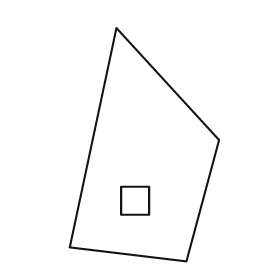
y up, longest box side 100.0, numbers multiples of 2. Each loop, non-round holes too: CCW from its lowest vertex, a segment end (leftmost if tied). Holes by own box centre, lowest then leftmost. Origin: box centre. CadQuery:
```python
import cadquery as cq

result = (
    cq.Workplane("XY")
    .moveTo(18.0, -50.0)
    .lineTo(32.0, 2.0)
    .lineTo(-12.0, 50.0)
    .lineTo(-32.0, -44.0)
    .close()
    .moveTo(-10.0, -30.0)
    .lineTo(2.0, -30.0)
    .lineTo(2.0, -18.0)
    .lineTo(-10.0, -18.0)
    .close()
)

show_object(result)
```